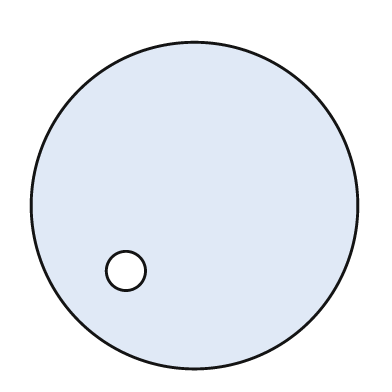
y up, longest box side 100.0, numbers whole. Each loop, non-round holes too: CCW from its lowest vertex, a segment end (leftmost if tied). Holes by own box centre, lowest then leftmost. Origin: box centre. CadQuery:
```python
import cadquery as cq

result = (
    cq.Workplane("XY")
    .moveTo(0.0, 0.0)
    .circle(50.0)
    .moveTo(-21.0, -20.0)
    .circle(6.0)
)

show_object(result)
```